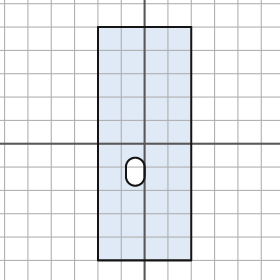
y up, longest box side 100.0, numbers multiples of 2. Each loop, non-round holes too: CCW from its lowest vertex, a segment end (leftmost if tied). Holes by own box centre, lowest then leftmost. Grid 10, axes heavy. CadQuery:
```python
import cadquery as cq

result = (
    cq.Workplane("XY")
    .moveTo(-20.0, -50.0)
    .lineTo(20.0, -50.0)
    .lineTo(20.0, 50.0)
    .lineTo(-20.0, 50.0)
    .close()
    .moveTo(-8.0, -14.0)
    .threePointArc((-4.0, -18.0), (0.0, -14.0))
    .lineTo(0.0, -10.0)
    .threePointArc((-4.0, -6.0), (-8.0, -10.0))
    .close()
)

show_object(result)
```